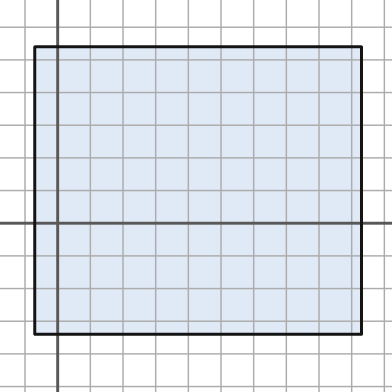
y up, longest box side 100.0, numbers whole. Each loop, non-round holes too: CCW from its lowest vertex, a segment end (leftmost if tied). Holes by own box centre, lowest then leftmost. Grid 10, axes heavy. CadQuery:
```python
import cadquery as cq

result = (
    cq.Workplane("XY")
    .moveTo(-7.0, -34.0)
    .lineTo(93.0, -34.0)
    .lineTo(93.0, 54.0)
    .lineTo(-7.0, 54.0)
    .close()
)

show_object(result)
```